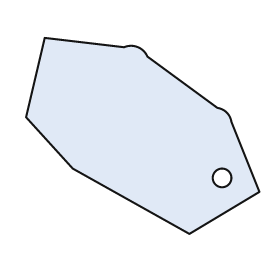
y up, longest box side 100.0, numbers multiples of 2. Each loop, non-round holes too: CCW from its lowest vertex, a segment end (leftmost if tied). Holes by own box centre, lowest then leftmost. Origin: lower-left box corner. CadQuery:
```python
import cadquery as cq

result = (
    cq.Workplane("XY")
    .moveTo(70.0, 0.0)
    .lineTo(100.0, 18.0)
    .lineTo(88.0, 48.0)
    .threePointArc((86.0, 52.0), (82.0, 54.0))
    .lineTo(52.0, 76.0)
    .threePointArc((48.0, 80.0), (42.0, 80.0))
    .lineTo(8.0, 84.0)
    .lineTo(0.0, 50.0)
    .lineTo(20.0, 28.0)
    .close()
    .moveTo(84.0, 24.0)
    .circle(4.0)
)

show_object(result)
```